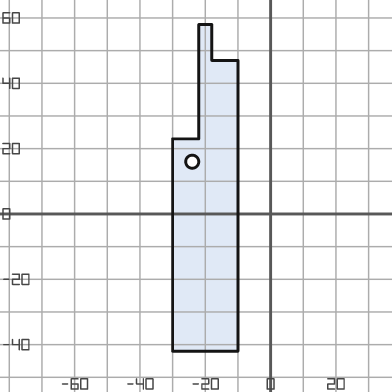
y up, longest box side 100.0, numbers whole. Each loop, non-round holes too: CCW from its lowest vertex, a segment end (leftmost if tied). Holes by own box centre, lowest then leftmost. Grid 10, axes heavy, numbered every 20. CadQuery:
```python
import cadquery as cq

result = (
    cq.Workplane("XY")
    .moveTo(-30.0, -42.0)
    .lineTo(-10.0, -42.0)
    .lineTo(-10.0, 47.0)
    .lineTo(-18.0, 47.0)
    .lineTo(-18.0, 58.0)
    .lineTo(-22.0, 58.0)
    .lineTo(-22.0, 23.0)
    .lineTo(-30.0, 23.0)
    .close()
    .moveTo(-24.0, 16.0)
    .circle(2.0)
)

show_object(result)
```